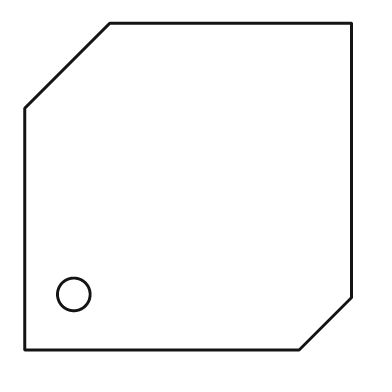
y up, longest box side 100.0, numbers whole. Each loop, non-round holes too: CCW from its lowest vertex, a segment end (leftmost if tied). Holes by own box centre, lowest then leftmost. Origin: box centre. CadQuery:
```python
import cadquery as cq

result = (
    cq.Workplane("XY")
    .moveTo(-50.0, -50.0)
    .lineTo(34.0, -50.0)
    .lineTo(50.0, -34.0)
    .lineTo(50.0, 50.0)
    .lineTo(-24.0, 50.0)
    .lineTo(-50.0, 24.0)
    .close()
    .moveTo(-35.0, -33.0)
    .circle(5.0)
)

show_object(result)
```